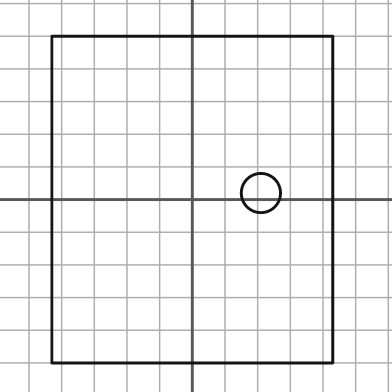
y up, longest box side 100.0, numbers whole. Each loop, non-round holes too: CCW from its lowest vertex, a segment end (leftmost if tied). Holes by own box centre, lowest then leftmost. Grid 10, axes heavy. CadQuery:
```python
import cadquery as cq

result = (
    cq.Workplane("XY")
    .moveTo(-43.0, -50.0)
    .lineTo(43.0, -50.0)
    .lineTo(43.0, 50.0)
    .lineTo(-43.0, 50.0)
    .close()
    .moveTo(21.0, 2.0)
    .circle(6.0)
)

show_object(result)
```